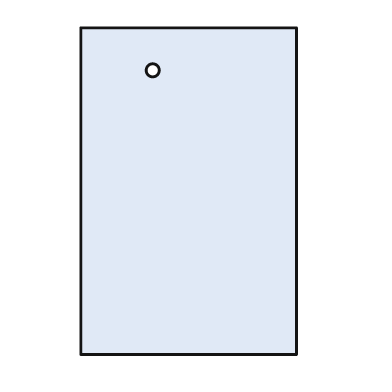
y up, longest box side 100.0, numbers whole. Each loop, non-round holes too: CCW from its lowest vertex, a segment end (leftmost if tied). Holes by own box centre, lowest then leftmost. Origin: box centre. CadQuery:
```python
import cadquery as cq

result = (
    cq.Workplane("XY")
    .moveTo(-33.0, -50.0)
    .lineTo(33.0, -50.0)
    .lineTo(33.0, 50.0)
    .lineTo(-33.0, 50.0)
    .close()
    .moveTo(-11.0, 37.0)
    .circle(2.0)
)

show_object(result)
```